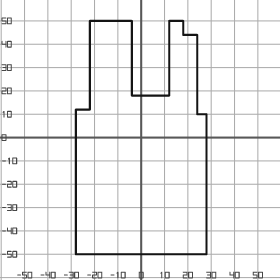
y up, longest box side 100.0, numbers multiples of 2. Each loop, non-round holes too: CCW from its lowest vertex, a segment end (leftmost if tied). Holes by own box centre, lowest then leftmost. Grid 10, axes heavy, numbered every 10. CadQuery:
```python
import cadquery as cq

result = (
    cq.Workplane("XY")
    .moveTo(-28.0, -50.0)
    .lineTo(28.0, -50.0)
    .lineTo(28.0, 10.0)
    .lineTo(24.0, 10.0)
    .lineTo(24.0, 44.0)
    .lineTo(18.0, 44.0)
    .lineTo(18.0, 50.0)
    .lineTo(12.0, 50.0)
    .lineTo(12.0, 18.0)
    .lineTo(-4.0, 18.0)
    .lineTo(-4.0, 50.0)
    .lineTo(-22.0, 50.0)
    .lineTo(-22.0, 12.0)
    .lineTo(-28.0, 12.0)
    .close()
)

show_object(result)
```